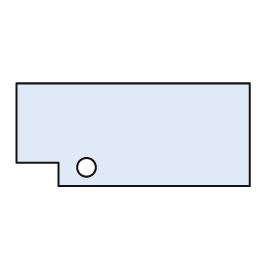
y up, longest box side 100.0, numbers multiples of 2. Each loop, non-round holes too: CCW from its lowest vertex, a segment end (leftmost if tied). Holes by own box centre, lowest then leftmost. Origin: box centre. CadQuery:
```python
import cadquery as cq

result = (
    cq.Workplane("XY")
    .moveTo(-32.0, -22.0)
    .lineTo(50.0, -22.0)
    .lineTo(50.0, 22.0)
    .lineTo(-50.0, 22.0)
    .lineTo(-50.0, -12.0)
    .lineTo(-32.0, -12.0)
    .close()
    .moveTo(-20.0, -14.0)
    .circle(4.0)
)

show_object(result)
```